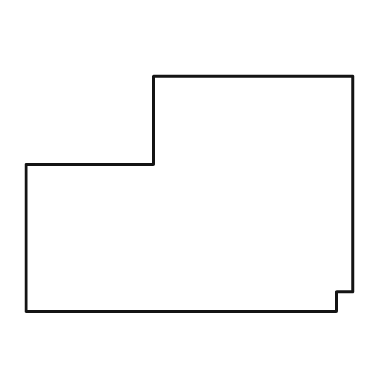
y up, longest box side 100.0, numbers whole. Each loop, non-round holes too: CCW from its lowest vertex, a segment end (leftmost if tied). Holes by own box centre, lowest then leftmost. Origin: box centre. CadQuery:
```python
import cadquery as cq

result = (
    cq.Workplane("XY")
    .moveTo(-50.0, -36.0)
    .lineTo(45.0, -36.0)
    .lineTo(45.0, -30.0)
    .lineTo(50.0, -30.0)
    .lineTo(50.0, 36.0)
    .lineTo(-11.0, 36.0)
    .lineTo(-11.0, 9.0)
    .lineTo(-50.0, 9.0)
    .close()
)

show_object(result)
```